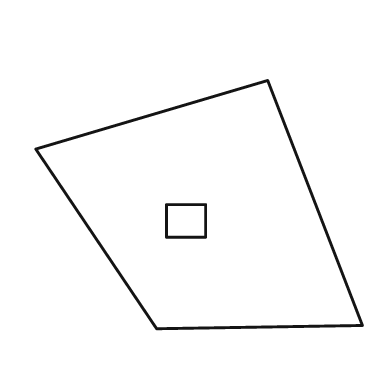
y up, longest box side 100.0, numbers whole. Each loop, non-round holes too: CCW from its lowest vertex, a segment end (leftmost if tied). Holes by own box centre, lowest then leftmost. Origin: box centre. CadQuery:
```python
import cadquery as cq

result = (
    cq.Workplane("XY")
    .moveTo(-13.0, -38.0)
    .lineTo(50.0, -37.0)
    .lineTo(21.0, 38.0)
    .lineTo(-50.0, 17.0)
    .close()
    .moveTo(-10.0, -10.0)
    .lineTo(2.0, -10.0)
    .lineTo(2.0, 0.0)
    .lineTo(-10.0, 0.0)
    .close()
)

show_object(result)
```